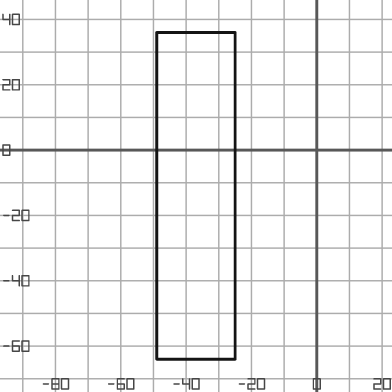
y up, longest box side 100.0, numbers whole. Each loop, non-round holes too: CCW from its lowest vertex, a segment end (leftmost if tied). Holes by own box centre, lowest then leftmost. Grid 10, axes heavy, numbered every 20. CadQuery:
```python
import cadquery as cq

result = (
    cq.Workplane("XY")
    .moveTo(-49.0, -64.0)
    .lineTo(-25.0, -64.0)
    .lineTo(-25.0, 36.0)
    .lineTo(-49.0, 36.0)
    .close()
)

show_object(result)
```